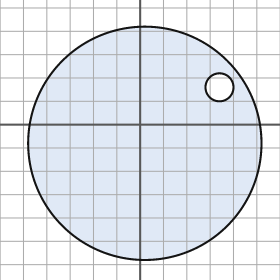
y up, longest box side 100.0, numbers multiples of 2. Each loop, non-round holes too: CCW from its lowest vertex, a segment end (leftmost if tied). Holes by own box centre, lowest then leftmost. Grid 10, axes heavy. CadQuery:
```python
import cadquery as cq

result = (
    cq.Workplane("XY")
    .moveTo(2.0, -8.0)
    .circle(50.0)
    .moveTo(34.0, 16.0)
    .circle(6.0)
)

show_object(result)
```